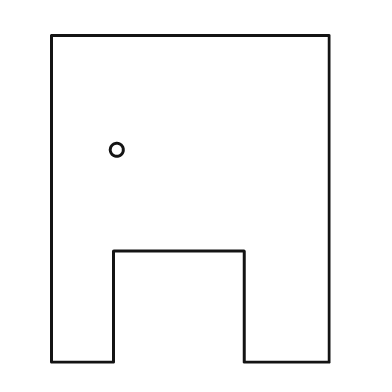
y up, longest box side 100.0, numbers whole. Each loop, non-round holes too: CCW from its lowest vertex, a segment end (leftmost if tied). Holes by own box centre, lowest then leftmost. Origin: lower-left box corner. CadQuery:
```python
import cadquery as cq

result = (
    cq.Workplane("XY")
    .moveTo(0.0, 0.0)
    .lineTo(19.0, 0.0)
    .lineTo(19.0, 34.0)
    .lineTo(59.0, 34.0)
    .lineTo(59.0, 0.0)
    .lineTo(85.0, 0.0)
    .lineTo(85.0, 100.0)
    .lineTo(0.0, 100.0)
    .close()
    .moveTo(20.0, 65.0)
    .circle(2.0)
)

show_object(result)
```